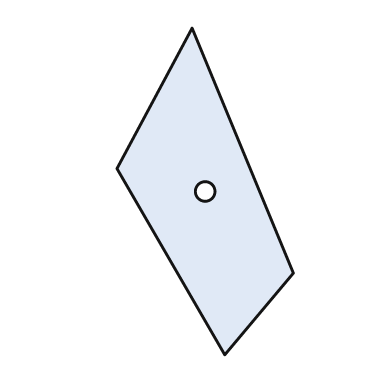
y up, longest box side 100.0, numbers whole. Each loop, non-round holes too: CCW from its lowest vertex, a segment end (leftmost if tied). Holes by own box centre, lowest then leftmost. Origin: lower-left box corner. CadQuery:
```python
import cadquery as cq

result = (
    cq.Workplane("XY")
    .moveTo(33.0, 0.0)
    .lineTo(54.0, 25.0)
    .lineTo(23.0, 100.0)
    .lineTo(0.0, 57.0)
    .close()
    .moveTo(27.0, 50.0)
    .circle(3.0)
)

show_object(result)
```